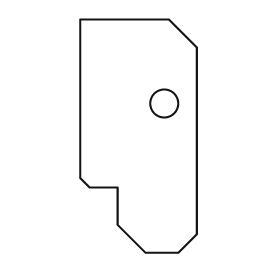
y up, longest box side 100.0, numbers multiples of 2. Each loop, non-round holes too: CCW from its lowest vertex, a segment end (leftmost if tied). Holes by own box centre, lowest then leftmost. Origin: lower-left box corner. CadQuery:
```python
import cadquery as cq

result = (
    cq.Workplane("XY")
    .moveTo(28.0, 0.0)
    .lineTo(42.0, 0.0)
    .lineTo(50.0, 8.0)
    .lineTo(50.0, 88.0)
    .lineTo(38.0, 100.0)
    .lineTo(0.0, 100.0)
    .lineTo(0.0, 32.0)
    .lineTo(4.0, 28.0)
    .lineTo(16.0, 28.0)
    .lineTo(16.0, 12.0)
    .close()
    .moveTo(36.0, 64.0)
    .circle(6.0)
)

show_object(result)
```